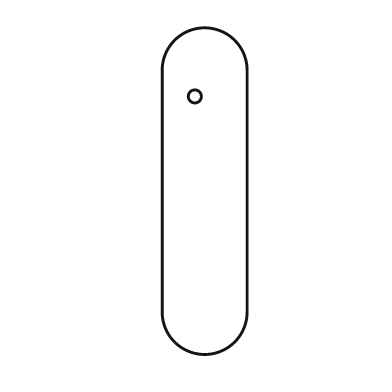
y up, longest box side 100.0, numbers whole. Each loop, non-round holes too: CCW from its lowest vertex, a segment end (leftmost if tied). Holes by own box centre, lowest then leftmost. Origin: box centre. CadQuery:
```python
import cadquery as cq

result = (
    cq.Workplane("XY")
    .moveTo(-13.0, -37.0)
    .threePointArc((0.0, -50.0), (13.0, -37.0))
    .lineTo(13.0, 37.0)
    .threePointArc((0.0, 50.0), (-13.0, 37.0))
    .close()
    .moveTo(-3.0, 29.0)
    .circle(2.0)
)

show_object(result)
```